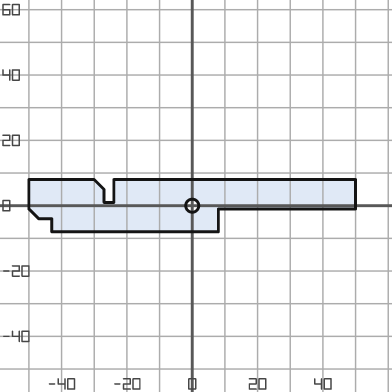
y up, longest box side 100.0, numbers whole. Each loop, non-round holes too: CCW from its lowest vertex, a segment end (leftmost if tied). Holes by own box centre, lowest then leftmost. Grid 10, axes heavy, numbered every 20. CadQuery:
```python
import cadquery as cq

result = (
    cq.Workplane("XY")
    .moveTo(-43.0, -8.0)
    .lineTo(8.0, -8.0)
    .lineTo(8.0, -1.0)
    .lineTo(50.0, -1.0)
    .lineTo(50.0, 8.0)
    .lineTo(-24.0, 8.0)
    .lineTo(-24.0, 1.0)
    .lineTo(-27.0, 1.0)
    .lineTo(-27.0, 5.0)
    .lineTo(-30.0, 8.0)
    .lineTo(-50.0, 8.0)
    .lineTo(-50.0, -1.0)
    .lineTo(-47.0, -4.0)
    .lineTo(-43.0, -4.0)
    .close()
    .moveTo(0.0, 0.0)
    .circle(2.0)
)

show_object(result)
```